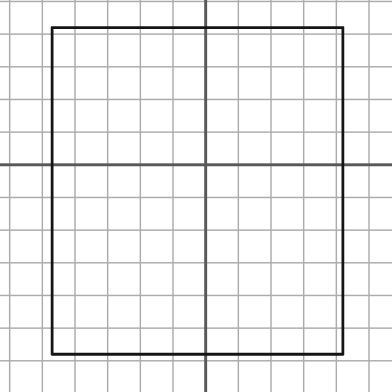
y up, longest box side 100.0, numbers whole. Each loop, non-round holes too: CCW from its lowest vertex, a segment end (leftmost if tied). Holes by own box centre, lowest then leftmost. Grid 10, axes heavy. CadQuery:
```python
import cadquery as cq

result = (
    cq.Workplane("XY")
    .moveTo(-47.0, -58.0)
    .lineTo(42.0, -58.0)
    .lineTo(42.0, 42.0)
    .lineTo(-47.0, 42.0)
    .close()
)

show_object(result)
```